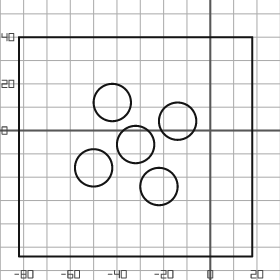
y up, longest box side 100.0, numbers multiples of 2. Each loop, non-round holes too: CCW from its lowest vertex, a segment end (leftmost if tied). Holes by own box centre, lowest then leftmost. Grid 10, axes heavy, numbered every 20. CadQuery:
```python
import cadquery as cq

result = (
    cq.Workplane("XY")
    .moveTo(-82.0, -54.0)
    .lineTo(18.0, -54.0)
    .lineTo(18.0, 40.0)
    .lineTo(-82.0, 40.0)
    .close()
    .moveTo(-22.0, -24.0)
    .circle(8.0)
    .moveTo(-50.0, -16.0)
    .circle(8.0)
    .moveTo(-32.0, -6.0)
    .circle(8.0)
    .moveTo(-14.0, 4.0)
    .circle(8.0)
    .moveTo(-42.0, 12.0)
    .circle(8.0)
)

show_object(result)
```